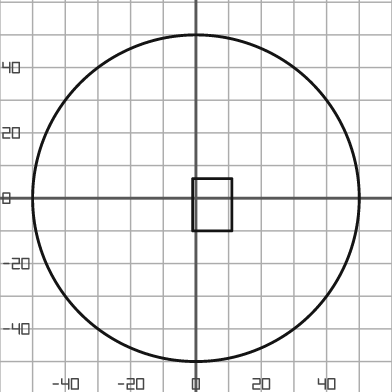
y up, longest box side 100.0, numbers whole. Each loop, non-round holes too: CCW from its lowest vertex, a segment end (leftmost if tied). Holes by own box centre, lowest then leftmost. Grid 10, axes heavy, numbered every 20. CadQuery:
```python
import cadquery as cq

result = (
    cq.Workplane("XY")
    .moveTo(0.0, 0.0)
    .circle(50.0)
    .moveTo(-1.0, -10.0)
    .lineTo(11.0, -10.0)
    .lineTo(11.0, 6.0)
    .lineTo(-1.0, 6.0)
    .close()
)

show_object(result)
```